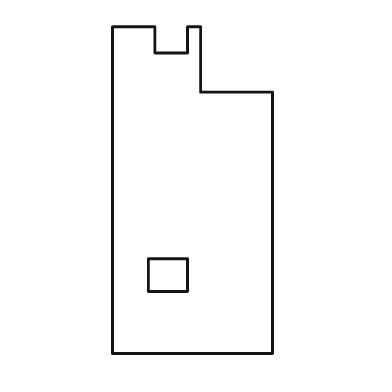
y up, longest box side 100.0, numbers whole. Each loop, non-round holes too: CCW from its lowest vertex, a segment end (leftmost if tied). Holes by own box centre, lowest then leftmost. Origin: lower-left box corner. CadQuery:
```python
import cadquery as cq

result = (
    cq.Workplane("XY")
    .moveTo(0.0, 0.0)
    .lineTo(49.0, 0.0)
    .lineTo(49.0, 80.0)
    .lineTo(27.0, 80.0)
    .lineTo(27.0, 100.0)
    .lineTo(23.0, 100.0)
    .lineTo(23.0, 92.0)
    .lineTo(13.0, 92.0)
    .lineTo(13.0, 100.0)
    .lineTo(0.0, 100.0)
    .close()
    .moveTo(11.0, 19.0)
    .lineTo(23.0, 19.0)
    .lineTo(23.0, 29.0)
    .lineTo(11.0, 29.0)
    .close()
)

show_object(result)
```